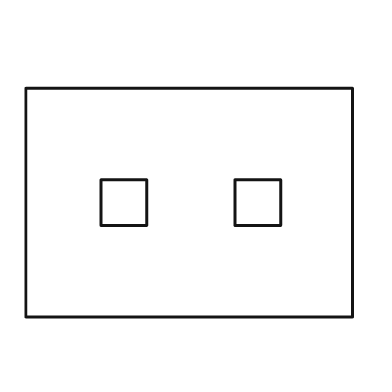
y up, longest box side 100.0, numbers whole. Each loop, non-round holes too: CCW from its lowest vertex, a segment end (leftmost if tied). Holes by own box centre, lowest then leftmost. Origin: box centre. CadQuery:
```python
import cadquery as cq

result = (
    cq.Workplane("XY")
    .moveTo(-50.0, -35.0)
    .lineTo(50.0, -35.0)
    .lineTo(50.0, 35.0)
    .lineTo(-50.0, 35.0)
    .close()
    .moveTo(-27.0, -7.0)
    .lineTo(-13.0, -7.0)
    .lineTo(-13.0, 7.0)
    .lineTo(-27.0, 7.0)
    .close()
    .moveTo(14.0, -7.0)
    .lineTo(28.0, -7.0)
    .lineTo(28.0, 7.0)
    .lineTo(14.0, 7.0)
    .close()
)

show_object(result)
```